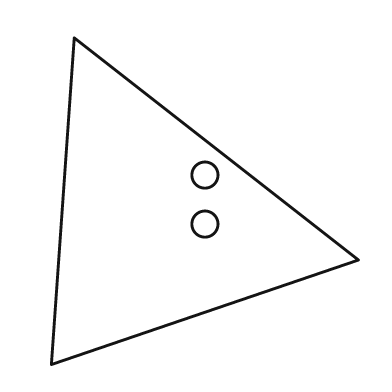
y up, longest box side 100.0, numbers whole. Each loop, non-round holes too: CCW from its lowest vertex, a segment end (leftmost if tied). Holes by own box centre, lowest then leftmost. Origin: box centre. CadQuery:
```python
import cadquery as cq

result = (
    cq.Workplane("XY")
    .moveTo(-47.0, -50.0)
    .lineTo(47.0, -18.0)
    .lineTo(-40.0, 50.0)
    .close()
    .moveTo(0.0, -7.0)
    .circle(4.0)
    .moveTo(0.0, 8.0)
    .circle(4.0)
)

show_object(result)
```